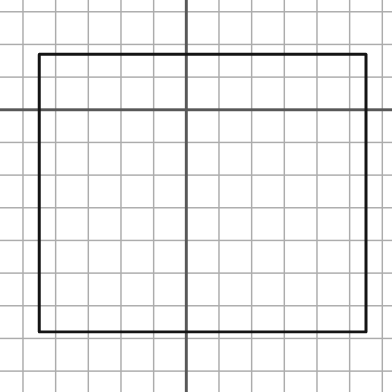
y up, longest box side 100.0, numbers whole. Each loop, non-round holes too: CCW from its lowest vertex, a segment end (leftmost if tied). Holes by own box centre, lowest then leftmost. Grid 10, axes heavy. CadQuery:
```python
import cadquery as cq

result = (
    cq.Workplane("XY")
    .moveTo(-45.0, -68.0)
    .lineTo(55.0, -68.0)
    .lineTo(55.0, 17.0)
    .lineTo(-45.0, 17.0)
    .close()
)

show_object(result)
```